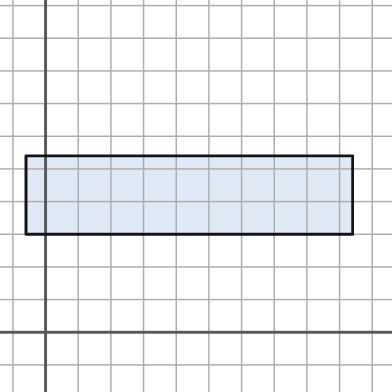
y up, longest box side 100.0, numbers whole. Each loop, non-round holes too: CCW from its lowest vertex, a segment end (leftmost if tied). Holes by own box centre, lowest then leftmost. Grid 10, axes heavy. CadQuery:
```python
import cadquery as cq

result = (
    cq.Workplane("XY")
    .moveTo(-6.0, 30.0)
    .lineTo(94.0, 30.0)
    .lineTo(94.0, 54.0)
    .lineTo(-6.0, 54.0)
    .close()
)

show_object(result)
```